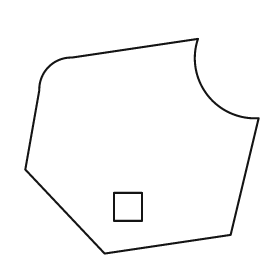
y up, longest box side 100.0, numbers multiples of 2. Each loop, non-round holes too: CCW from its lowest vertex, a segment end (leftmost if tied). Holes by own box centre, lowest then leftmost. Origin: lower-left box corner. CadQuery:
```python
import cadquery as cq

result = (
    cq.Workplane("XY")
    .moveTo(34.0, 0.0)
    .lineTo(88.0, 8.0)
    .lineTo(100.0, 58.0)
    .threePointArc((78.0, 68.0), (74.0, 92.0))
    .lineTo(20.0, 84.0)
    .threePointArc((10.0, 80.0), (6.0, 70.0))
    .lineTo(0.0, 36.0)
    .close()
    .moveTo(38.0, 14.0)
    .lineTo(50.0, 14.0)
    .lineTo(50.0, 26.0)
    .lineTo(38.0, 26.0)
    .close()
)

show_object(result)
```